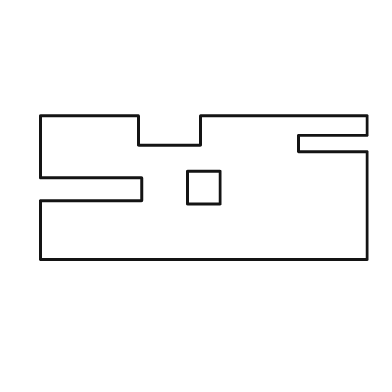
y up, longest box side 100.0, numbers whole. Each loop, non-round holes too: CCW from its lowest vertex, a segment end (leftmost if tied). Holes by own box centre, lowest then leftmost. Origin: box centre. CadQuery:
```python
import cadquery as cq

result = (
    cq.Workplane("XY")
    .moveTo(-50.0, -22.0)
    .lineTo(50.0, -22.0)
    .lineTo(50.0, 11.0)
    .lineTo(29.0, 11.0)
    .lineTo(29.0, 16.0)
    .lineTo(50.0, 16.0)
    .lineTo(50.0, 22.0)
    .lineTo(-1.0, 22.0)
    .lineTo(-1.0, 13.0)
    .lineTo(-20.0, 13.0)
    .lineTo(-20.0, 22.0)
    .lineTo(-50.0, 22.0)
    .lineTo(-50.0, 3.0)
    .lineTo(-19.0, 3.0)
    .lineTo(-19.0, -4.0)
    .lineTo(-50.0, -4.0)
    .close()
    .moveTo(-5.0, -5.0)
    .lineTo(5.0, -5.0)
    .lineTo(5.0, 5.0)
    .lineTo(-5.0, 5.0)
    .close()
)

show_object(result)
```